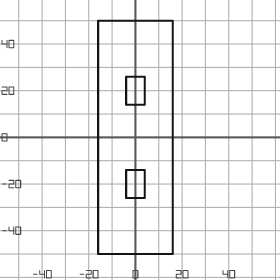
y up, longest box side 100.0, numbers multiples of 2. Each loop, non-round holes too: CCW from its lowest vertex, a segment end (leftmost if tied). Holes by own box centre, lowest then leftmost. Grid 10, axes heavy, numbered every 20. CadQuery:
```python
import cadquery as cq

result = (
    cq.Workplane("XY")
    .moveTo(-16.0, -50.0)
    .lineTo(16.0, -50.0)
    .lineTo(16.0, 50.0)
    .lineTo(-16.0, 50.0)
    .close()
    .moveTo(-4.0, -26.0)
    .lineTo(4.0, -26.0)
    .lineTo(4.0, -14.0)
    .lineTo(-4.0, -14.0)
    .close()
    .moveTo(-4.0, 14.0)
    .lineTo(4.0, 14.0)
    .lineTo(4.0, 26.0)
    .lineTo(-4.0, 26.0)
    .close()
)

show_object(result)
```